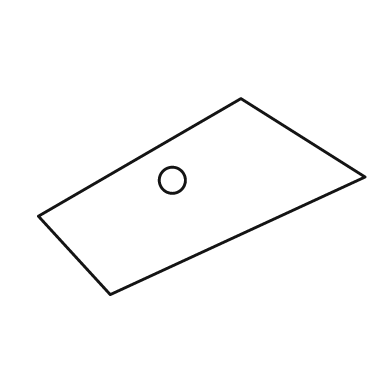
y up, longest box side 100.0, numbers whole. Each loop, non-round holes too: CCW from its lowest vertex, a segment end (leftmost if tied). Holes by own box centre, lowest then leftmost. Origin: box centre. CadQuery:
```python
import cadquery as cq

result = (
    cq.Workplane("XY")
    .moveTo(-28.0, -30.0)
    .lineTo(50.0, 6.0)
    .lineTo(12.0, 30.0)
    .lineTo(-50.0, -6.0)
    .close()
    .moveTo(-9.0, 5.0)
    .circle(4.0)
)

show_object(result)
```